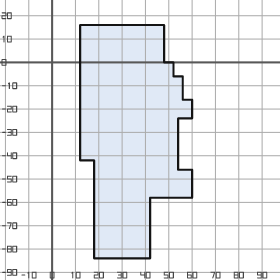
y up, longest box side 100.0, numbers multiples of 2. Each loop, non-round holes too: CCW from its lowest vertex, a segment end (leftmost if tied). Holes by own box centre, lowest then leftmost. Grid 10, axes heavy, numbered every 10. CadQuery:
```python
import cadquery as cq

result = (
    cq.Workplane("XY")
    .moveTo(18.0, -84.0)
    .lineTo(42.0, -84.0)
    .lineTo(42.0, -58.0)
    .lineTo(60.0, -58.0)
    .lineTo(60.0, -46.0)
    .lineTo(54.0, -46.0)
    .lineTo(54.0, -24.0)
    .lineTo(60.0, -24.0)
    .lineTo(60.0, -16.0)
    .lineTo(56.0, -16.0)
    .lineTo(56.0, -6.0)
    .lineTo(52.0, -6.0)
    .lineTo(52.0, 0.0)
    .lineTo(48.0, 0.0)
    .lineTo(48.0, 16.0)
    .lineTo(12.0, 16.0)
    .lineTo(12.0, -42.0)
    .lineTo(18.0, -42.0)
    .close()
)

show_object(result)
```